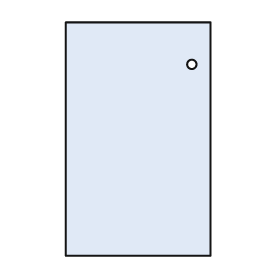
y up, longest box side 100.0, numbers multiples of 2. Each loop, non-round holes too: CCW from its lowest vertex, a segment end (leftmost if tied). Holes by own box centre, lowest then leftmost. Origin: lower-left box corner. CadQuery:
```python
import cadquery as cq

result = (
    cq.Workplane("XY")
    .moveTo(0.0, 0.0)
    .lineTo(62.0, 0.0)
    .lineTo(62.0, 100.0)
    .lineTo(0.0, 100.0)
    .close()
    .moveTo(54.0, 82.0)
    .circle(2.0)
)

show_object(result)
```